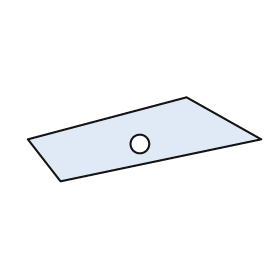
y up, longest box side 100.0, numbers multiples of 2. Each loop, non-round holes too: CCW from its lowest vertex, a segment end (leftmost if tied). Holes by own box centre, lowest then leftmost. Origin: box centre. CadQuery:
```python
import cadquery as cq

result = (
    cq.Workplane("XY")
    .moveTo(-36.0, -18.0)
    .lineTo(50.0, 0.0)
    .lineTo(18.0, 18.0)
    .lineTo(-50.0, 0.0)
    .close()
    .moveTo(-2.0, -2.0)
    .circle(4.0)
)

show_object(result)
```